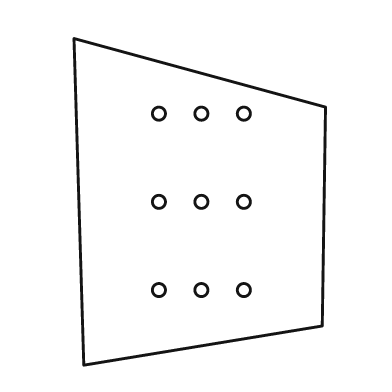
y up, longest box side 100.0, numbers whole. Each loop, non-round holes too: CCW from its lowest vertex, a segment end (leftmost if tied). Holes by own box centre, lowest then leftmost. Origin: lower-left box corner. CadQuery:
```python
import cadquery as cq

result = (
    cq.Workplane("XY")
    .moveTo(3.0, 0.0)
    .lineTo(76.0, 12.0)
    .lineTo(77.0, 79.0)
    .lineTo(0.0, 100.0)
    .close()
    .moveTo(26.0, 23.0)
    .circle(2.0)
    .moveTo(39.0, 23.0)
    .circle(2.0)
    .moveTo(52.0, 23.0)
    .circle(2.0)
    .moveTo(26.0, 50.0)
    .circle(2.0)
    .moveTo(39.0, 50.0)
    .circle(2.0)
    .moveTo(52.0, 50.0)
    .circle(2.0)
    .moveTo(26.0, 77.0)
    .circle(2.0)
    .moveTo(39.0, 77.0)
    .circle(2.0)
    .moveTo(52.0, 77.0)
    .circle(2.0)
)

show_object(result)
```